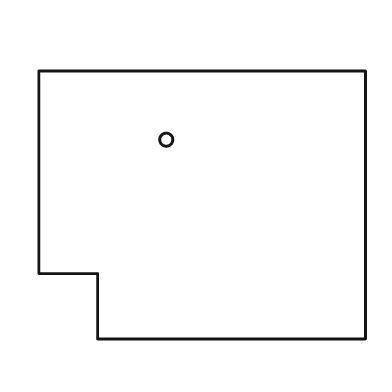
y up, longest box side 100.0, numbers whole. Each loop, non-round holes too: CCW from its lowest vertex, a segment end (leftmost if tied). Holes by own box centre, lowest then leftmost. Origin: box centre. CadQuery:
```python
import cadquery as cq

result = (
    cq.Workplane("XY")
    .moveTo(-32.0, -41.0)
    .lineTo(50.0, -41.0)
    .lineTo(50.0, 41.0)
    .lineTo(-50.0, 41.0)
    .lineTo(-50.0, -21.0)
    .lineTo(-32.0, -21.0)
    .close()
    .moveTo(-11.0, 20.0)
    .circle(2.0)
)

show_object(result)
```